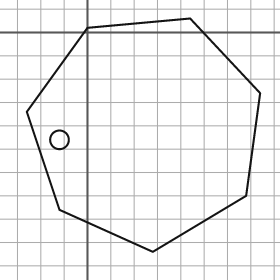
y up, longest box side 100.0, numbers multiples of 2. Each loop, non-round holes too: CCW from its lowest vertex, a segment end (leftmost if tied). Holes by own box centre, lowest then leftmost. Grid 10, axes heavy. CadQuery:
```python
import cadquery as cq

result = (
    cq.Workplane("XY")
    .moveTo(28.0, -94.0)
    .lineTo(68.0, -70.0)
    .lineTo(74.0, -26.0)
    .lineTo(44.0, 6.0)
    .lineTo(0.0, 2.0)
    .lineTo(-26.0, -34.0)
    .lineTo(-12.0, -76.0)
    .close()
    .moveTo(-12.0, -46.0)
    .circle(4.0)
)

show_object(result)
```